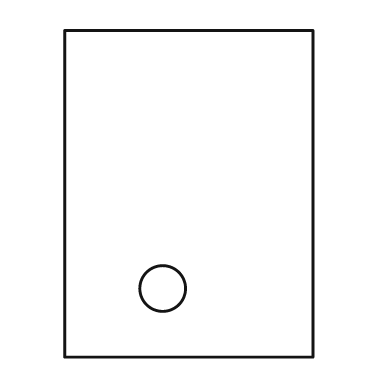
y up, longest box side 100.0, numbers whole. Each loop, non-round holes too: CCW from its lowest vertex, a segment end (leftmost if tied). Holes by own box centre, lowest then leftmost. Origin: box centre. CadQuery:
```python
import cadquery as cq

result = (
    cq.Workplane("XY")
    .moveTo(-38.0, -50.0)
    .lineTo(38.0, -50.0)
    .lineTo(38.0, 50.0)
    .lineTo(-38.0, 50.0)
    .close()
    .moveTo(-8.0, -29.0)
    .circle(7.0)
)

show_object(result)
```